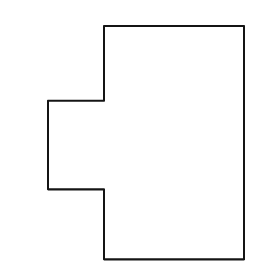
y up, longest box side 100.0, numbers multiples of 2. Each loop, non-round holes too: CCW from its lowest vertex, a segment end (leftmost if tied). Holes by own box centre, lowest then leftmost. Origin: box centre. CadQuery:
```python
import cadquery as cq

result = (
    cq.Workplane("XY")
    .moveTo(-18.0, -50.0)
    .lineTo(42.0, -50.0)
    .lineTo(42.0, 50.0)
    .lineTo(-18.0, 50.0)
    .lineTo(-18.0, 18.0)
    .lineTo(-42.0, 18.0)
    .lineTo(-42.0, -20.0)
    .lineTo(-18.0, -20.0)
    .close()
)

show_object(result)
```